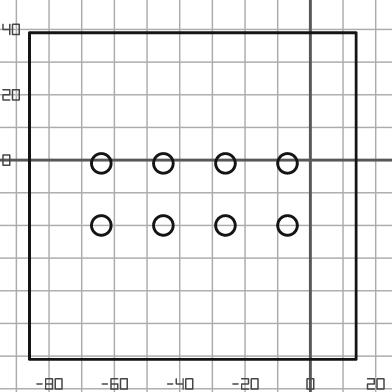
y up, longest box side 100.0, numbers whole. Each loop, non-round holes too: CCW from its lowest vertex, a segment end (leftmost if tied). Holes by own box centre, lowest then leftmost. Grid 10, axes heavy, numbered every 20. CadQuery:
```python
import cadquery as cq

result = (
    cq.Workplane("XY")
    .moveTo(-86.0, -61.0)
    .lineTo(14.0, -61.0)
    .lineTo(14.0, 39.0)
    .lineTo(-86.0, 39.0)
    .close()
    .moveTo(-64.0, -20.0)
    .circle(3.0)
    .moveTo(-45.0, -20.0)
    .circle(3.0)
    .moveTo(-26.0, -20.0)
    .circle(3.0)
    .moveTo(-7.0, -20.0)
    .circle(3.0)
    .moveTo(-64.0, -1.0)
    .circle(3.0)
    .moveTo(-45.0, -1.0)
    .circle(3.0)
    .moveTo(-26.0, -1.0)
    .circle(3.0)
    .moveTo(-7.0, -1.0)
    .circle(3.0)
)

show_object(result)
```